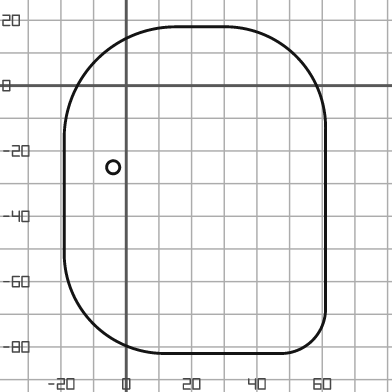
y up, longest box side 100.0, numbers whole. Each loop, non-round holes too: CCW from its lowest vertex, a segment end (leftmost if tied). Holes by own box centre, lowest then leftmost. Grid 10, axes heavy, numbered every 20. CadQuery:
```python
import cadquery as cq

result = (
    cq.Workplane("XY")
    .moveTo(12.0, -82.0)
    .lineTo(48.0, -82.0)
    .threePointArc((57.0, -78.0), (61.0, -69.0))
    .lineTo(61.0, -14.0)
    .threePointArc((52.0, 9.0), (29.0, 18.0))
    .lineTo(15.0, 18.0)
    .threePointArc((-9.0, 8.0), (-19.0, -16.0))
    .lineTo(-19.0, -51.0)
    .threePointArc((-10.0, -73.0), (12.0, -82.0))
    .close()
    .moveTo(-4.0, -25.0)
    .circle(2.0)
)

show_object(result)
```